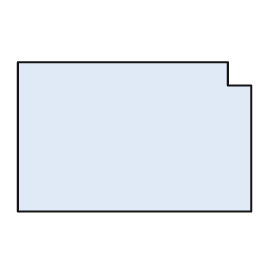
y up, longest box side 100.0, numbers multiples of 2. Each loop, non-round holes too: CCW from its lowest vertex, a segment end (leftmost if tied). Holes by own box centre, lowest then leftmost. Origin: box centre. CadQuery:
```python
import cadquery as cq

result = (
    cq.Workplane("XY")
    .moveTo(-50.0, -32.0)
    .lineTo(50.0, -32.0)
    .lineTo(50.0, 22.0)
    .lineTo(40.0, 22.0)
    .lineTo(40.0, 32.0)
    .lineTo(-50.0, 32.0)
    .close()
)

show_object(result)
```